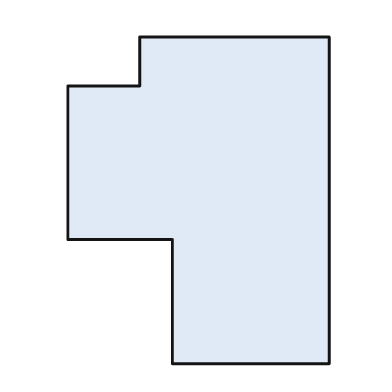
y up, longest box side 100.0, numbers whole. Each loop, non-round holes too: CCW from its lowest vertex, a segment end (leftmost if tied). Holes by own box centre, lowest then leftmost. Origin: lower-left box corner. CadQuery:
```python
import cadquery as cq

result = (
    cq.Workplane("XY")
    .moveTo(32.0, 0.0)
    .lineTo(80.0, 0.0)
    .lineTo(80.0, 100.0)
    .lineTo(22.0, 100.0)
    .lineTo(22.0, 85.0)
    .lineTo(0.0, 85.0)
    .lineTo(0.0, 38.0)
    .lineTo(32.0, 38.0)
    .close()
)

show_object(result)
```